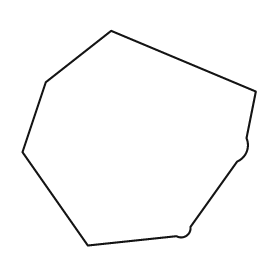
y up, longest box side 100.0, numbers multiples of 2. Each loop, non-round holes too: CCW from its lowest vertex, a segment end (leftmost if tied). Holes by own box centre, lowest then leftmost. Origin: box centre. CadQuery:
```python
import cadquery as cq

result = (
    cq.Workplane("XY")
    .moveTo(-22.0, -46.0)
    .lineTo(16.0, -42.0)
    .threePointArc((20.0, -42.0), (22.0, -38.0))
    .lineTo(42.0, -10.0)
    .threePointArc((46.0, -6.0), (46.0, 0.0))
    .lineTo(50.0, 20.0)
    .lineTo(-12.0, 46.0)
    .lineTo(-40.0, 24.0)
    .lineTo(-50.0, -6.0)
    .close()
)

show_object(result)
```